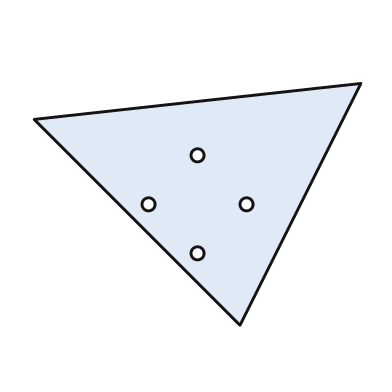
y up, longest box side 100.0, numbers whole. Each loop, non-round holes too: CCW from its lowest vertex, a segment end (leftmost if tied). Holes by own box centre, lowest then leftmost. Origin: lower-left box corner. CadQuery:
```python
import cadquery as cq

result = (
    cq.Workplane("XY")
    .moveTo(63.0, 0.0)
    .lineTo(100.0, 74.0)
    .lineTo(0.0, 63.0)
    .close()
    .moveTo(50.0, 22.0)
    .circle(2.0)
    .moveTo(35.0, 37.0)
    .circle(2.0)
    .moveTo(65.0, 37.0)
    .circle(2.0)
    .moveTo(50.0, 52.0)
    .circle(2.0)
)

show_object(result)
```